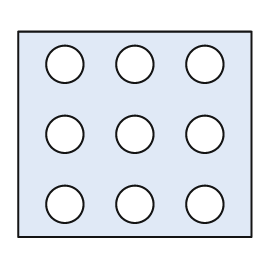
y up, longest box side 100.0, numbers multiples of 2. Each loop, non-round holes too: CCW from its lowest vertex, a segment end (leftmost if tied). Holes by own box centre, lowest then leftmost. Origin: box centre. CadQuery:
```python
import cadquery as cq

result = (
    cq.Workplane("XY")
    .moveTo(-50.0, -44.0)
    .lineTo(50.0, -44.0)
    .lineTo(50.0, 44.0)
    .lineTo(-50.0, 44.0)
    .close()
    .moveTo(-30.0, -30.0)
    .circle(8.0)
    .moveTo(0.0, -30.0)
    .circle(8.0)
    .moveTo(30.0, -30.0)
    .circle(8.0)
    .moveTo(-30.0, 0.0)
    .circle(8.0)
    .moveTo(0.0, 0.0)
    .circle(8.0)
    .moveTo(30.0, 0.0)
    .circle(8.0)
    .moveTo(-30.0, 30.0)
    .circle(8.0)
    .moveTo(0.0, 30.0)
    .circle(8.0)
    .moveTo(30.0, 30.0)
    .circle(8.0)
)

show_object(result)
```